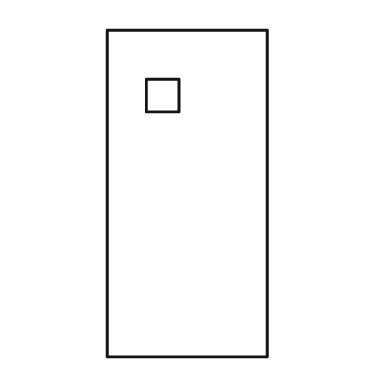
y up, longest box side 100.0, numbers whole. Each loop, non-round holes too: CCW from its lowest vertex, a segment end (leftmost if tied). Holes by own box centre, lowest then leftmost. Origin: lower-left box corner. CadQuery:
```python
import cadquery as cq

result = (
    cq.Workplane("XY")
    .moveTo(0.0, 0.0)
    .lineTo(49.0, 0.0)
    .lineTo(49.0, 100.0)
    .lineTo(0.0, 100.0)
    .close()
    .moveTo(12.0, 75.0)
    .lineTo(22.0, 75.0)
    .lineTo(22.0, 85.0)
    .lineTo(12.0, 85.0)
    .close()
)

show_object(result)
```